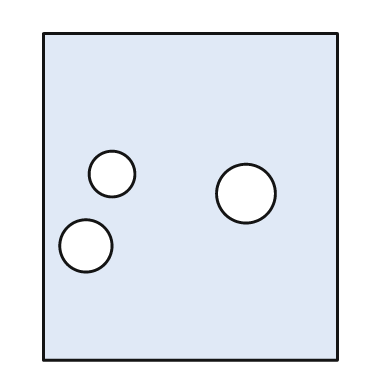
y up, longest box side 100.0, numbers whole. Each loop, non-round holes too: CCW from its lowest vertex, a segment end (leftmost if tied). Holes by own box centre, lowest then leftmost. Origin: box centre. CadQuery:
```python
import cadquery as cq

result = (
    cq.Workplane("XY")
    .moveTo(-45.0, -50.0)
    .lineTo(45.0, -50.0)
    .lineTo(45.0, 50.0)
    .lineTo(-45.0, 50.0)
    .close()
    .moveTo(-32.0, -15.0)
    .circle(8.0)
    .moveTo(17.0, 1.0)
    .circle(9.0)
    .moveTo(-24.0, 7.0)
    .circle(7.0)
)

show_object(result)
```